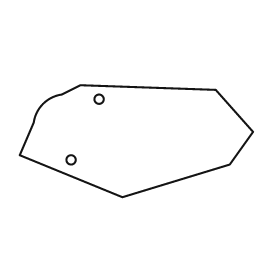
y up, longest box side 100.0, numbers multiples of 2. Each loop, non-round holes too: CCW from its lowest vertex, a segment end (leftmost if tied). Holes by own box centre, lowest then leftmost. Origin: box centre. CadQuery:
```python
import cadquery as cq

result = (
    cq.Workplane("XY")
    .moveTo(-6.0, -24.0)
    .lineTo(40.0, -10.0)
    .lineTo(50.0, 4.0)
    .lineTo(34.0, 22.0)
    .lineTo(-24.0, 24.0)
    .lineTo(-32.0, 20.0)
    .threePointArc((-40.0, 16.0), (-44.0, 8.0))
    .lineTo(-50.0, -6.0)
    .close()
    .moveTo(-28.0, -8.0)
    .circle(2.0)
    .moveTo(-16.0, 18.0)
    .circle(2.0)
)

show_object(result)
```